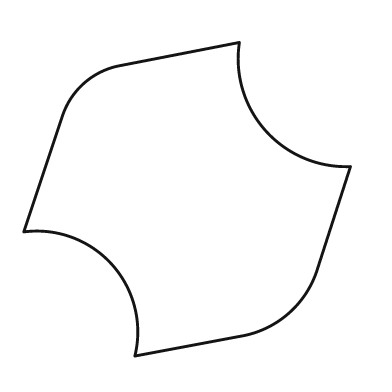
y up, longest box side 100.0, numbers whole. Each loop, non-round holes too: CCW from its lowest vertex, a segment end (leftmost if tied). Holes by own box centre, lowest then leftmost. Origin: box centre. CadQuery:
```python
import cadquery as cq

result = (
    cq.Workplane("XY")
    .moveTo(-16.0, -48.0)
    .lineTo(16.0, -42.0)
    .threePointArc((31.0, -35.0), (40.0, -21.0))
    .lineTo(50.0, 10.0)
    .threePointArc((24.0, 21.0), (16.0, 48.0))
    .lineTo(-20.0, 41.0)
    .threePointArc((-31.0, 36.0), (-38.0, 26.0))
    .lineTo(-50.0, -10.0)
    .threePointArc((-23.0, -20.0), (-16.0, -48.0))
    .close()
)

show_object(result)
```